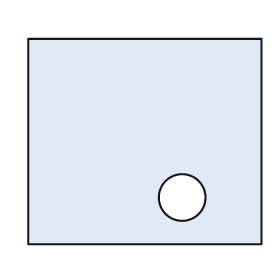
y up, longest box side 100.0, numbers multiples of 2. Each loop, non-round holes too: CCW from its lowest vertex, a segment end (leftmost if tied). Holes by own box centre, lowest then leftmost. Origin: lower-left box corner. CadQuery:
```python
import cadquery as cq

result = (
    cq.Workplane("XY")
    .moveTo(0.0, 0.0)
    .lineTo(100.0, 0.0)
    .lineTo(100.0, 88.0)
    .lineTo(0.0, 88.0)
    .close()
    .moveTo(66.0, 20.0)
    .circle(10.0)
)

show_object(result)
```